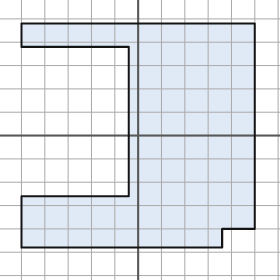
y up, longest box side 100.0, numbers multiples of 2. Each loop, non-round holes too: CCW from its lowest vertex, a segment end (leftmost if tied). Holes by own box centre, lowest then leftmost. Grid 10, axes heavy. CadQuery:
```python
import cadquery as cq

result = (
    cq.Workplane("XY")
    .moveTo(-50.0, -48.0)
    .lineTo(36.0, -48.0)
    .lineTo(36.0, -40.0)
    .lineTo(50.0, -40.0)
    .lineTo(50.0, 48.0)
    .lineTo(-50.0, 48.0)
    .lineTo(-50.0, 38.0)
    .lineTo(-4.0, 38.0)
    .lineTo(-4.0, -26.0)
    .lineTo(-50.0, -26.0)
    .close()
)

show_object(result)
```